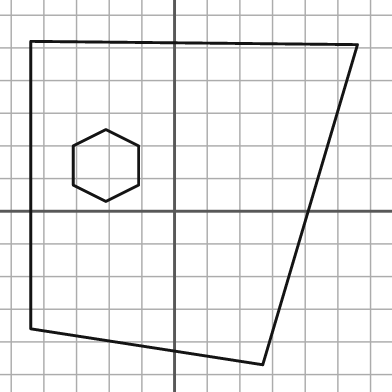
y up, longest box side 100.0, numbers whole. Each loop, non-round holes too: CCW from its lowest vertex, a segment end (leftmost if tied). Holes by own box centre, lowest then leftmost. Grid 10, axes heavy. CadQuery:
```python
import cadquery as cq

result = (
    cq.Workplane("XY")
    .moveTo(27.0, -47.0)
    .lineTo(56.0, 51.0)
    .lineTo(-44.0, 52.0)
    .lineTo(-44.0, -36.0)
    .close()
    .moveTo(-21.0, 3.0)
    .lineTo(-11.0, 8.0)
    .lineTo(-11.0, 20.0)
    .lineTo(-21.0, 25.0)
    .lineTo(-31.0, 20.0)
    .lineTo(-31.0, 8.0)
    .close()
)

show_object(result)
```